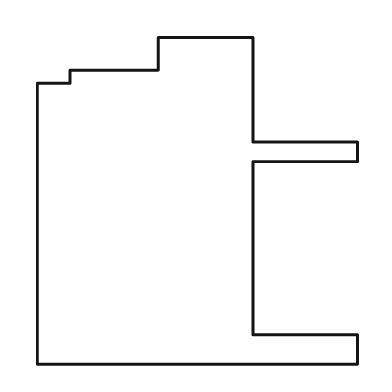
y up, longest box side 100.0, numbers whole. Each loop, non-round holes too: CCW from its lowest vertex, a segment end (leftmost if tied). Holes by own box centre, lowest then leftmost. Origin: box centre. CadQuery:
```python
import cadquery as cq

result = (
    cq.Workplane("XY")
    .moveTo(-49.0, -50.0)
    .lineTo(49.0, -50.0)
    .lineTo(49.0, -41.0)
    .lineTo(17.0, -41.0)
    .lineTo(17.0, 12.0)
    .lineTo(49.0, 12.0)
    .lineTo(49.0, 18.0)
    .lineTo(17.0, 18.0)
    .lineTo(17.0, 50.0)
    .lineTo(-12.0, 50.0)
    .lineTo(-12.0, 40.0)
    .lineTo(-39.0, 40.0)
    .lineTo(-39.0, 36.0)
    .lineTo(-49.0, 36.0)
    .close()
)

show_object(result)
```